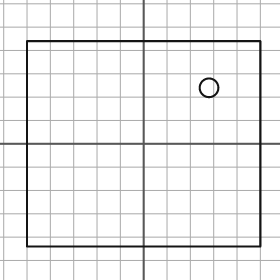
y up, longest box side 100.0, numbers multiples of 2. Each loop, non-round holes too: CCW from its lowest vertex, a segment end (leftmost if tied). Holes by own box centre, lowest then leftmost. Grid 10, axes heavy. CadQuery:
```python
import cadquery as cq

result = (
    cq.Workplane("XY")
    .moveTo(-50.0, -44.0)
    .lineTo(50.0, -44.0)
    .lineTo(50.0, 44.0)
    .lineTo(-50.0, 44.0)
    .close()
    .moveTo(28.0, 24.0)
    .circle(4.0)
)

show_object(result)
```